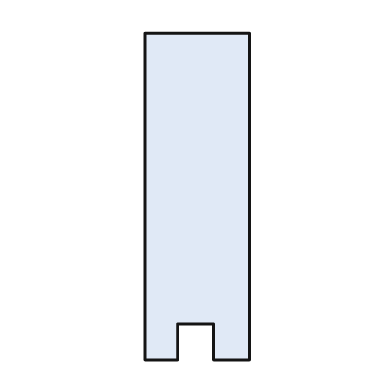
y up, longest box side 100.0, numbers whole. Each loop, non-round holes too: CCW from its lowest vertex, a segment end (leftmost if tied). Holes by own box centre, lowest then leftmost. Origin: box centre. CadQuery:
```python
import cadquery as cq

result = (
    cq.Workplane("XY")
    .moveTo(-16.0, -50.0)
    .lineTo(-6.0, -50.0)
    .lineTo(-6.0, -39.0)
    .lineTo(5.0, -39.0)
    .lineTo(5.0, -50.0)
    .lineTo(16.0, -50.0)
    .lineTo(16.0, 50.0)
    .lineTo(-16.0, 50.0)
    .close()
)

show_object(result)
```